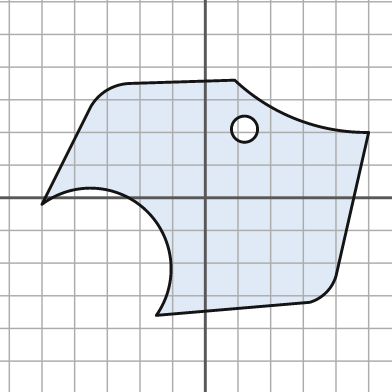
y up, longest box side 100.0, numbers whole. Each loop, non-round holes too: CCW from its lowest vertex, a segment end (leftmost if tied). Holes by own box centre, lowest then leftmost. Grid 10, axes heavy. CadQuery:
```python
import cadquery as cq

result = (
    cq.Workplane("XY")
    .moveTo(-15.0, -36.0)
    .lineTo(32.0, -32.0)
    .threePointArc((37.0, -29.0), (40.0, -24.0))
    .lineTo(50.0, 20.0)
    .threePointArc((28.0, 24.0), (9.0, 36.0))
    .lineTo(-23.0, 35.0)
    .threePointArc((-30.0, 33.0), (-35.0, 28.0))
    .lineTo(-50.0, -2.0)
    .threePointArc((-18.0, -4.0), (-15.0, -36.0))
    .close()
    .moveTo(12.0, 21.0)
    .circle(4.0)
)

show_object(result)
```